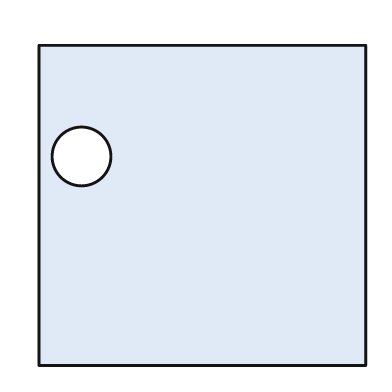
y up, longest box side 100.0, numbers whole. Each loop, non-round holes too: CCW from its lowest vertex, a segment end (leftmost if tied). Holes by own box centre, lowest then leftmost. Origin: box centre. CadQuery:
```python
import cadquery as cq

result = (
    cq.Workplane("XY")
    .moveTo(-50.0, -49.0)
    .lineTo(50.0, -49.0)
    .lineTo(50.0, 49.0)
    .lineTo(-50.0, 49.0)
    .close()
    .moveTo(-37.0, 15.0)
    .circle(9.0)
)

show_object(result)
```